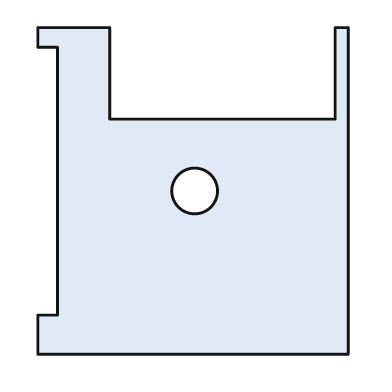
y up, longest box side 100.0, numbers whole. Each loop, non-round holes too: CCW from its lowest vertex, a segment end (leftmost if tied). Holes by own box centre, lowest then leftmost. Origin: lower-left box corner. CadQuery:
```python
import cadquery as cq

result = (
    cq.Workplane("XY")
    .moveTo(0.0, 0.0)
    .lineTo(95.0, 0.0)
    .lineTo(95.0, 100.0)
    .lineTo(91.0, 100.0)
    .lineTo(91.0, 72.0)
    .lineTo(22.0, 72.0)
    .lineTo(22.0, 100.0)
    .lineTo(0.0, 100.0)
    .lineTo(0.0, 94.0)
    .lineTo(6.0, 94.0)
    .lineTo(6.0, 12.0)
    .lineTo(0.0, 12.0)
    .close()
    .moveTo(48.0, 50.0)
    .circle(7.0)
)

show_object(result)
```